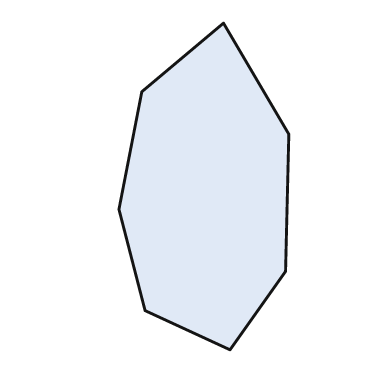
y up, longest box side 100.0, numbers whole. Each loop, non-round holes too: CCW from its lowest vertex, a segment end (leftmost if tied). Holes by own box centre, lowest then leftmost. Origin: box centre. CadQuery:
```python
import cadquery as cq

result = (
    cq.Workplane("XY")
    .moveTo(8.0, -50.0)
    .lineTo(25.0, -26.0)
    .lineTo(26.0, 16.0)
    .lineTo(6.0, 50.0)
    .lineTo(-19.0, 29.0)
    .lineTo(-26.0, -7.0)
    .lineTo(-18.0, -38.0)
    .close()
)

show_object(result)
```